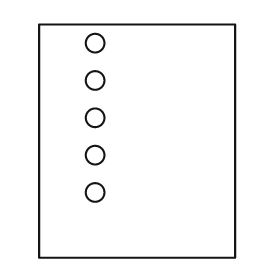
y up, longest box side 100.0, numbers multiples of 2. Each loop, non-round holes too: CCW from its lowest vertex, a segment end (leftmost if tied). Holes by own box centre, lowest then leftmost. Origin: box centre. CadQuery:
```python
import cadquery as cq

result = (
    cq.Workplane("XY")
    .moveTo(-42.0, -50.0)
    .lineTo(42.0, -50.0)
    .lineTo(42.0, 50.0)
    .lineTo(-42.0, 50.0)
    .close()
    .moveTo(-18.0, -22.0)
    .circle(4.0)
    .moveTo(-18.0, -6.0)
    .circle(4.0)
    .moveTo(-18.0, 10.0)
    .circle(4.0)
    .moveTo(-18.0, 26.0)
    .circle(4.0)
    .moveTo(-18.0, 42.0)
    .circle(4.0)
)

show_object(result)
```